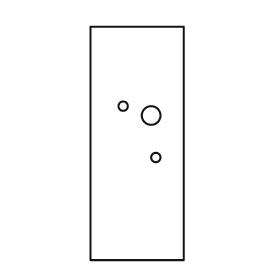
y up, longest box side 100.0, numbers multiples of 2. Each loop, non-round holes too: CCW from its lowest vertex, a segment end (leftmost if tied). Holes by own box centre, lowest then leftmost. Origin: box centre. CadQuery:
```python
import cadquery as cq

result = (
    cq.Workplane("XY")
    .moveTo(-20.0, -50.0)
    .lineTo(20.0, -50.0)
    .lineTo(20.0, 50.0)
    .lineTo(-20.0, 50.0)
    .close()
    .moveTo(8.0, -6.0)
    .circle(2.0)
    .moveTo(6.0, 12.0)
    .circle(4.0)
    .moveTo(-6.0, 16.0)
    .circle(2.0)
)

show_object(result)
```